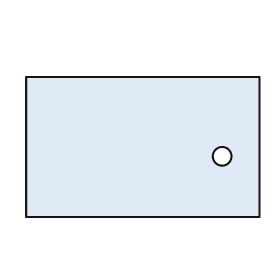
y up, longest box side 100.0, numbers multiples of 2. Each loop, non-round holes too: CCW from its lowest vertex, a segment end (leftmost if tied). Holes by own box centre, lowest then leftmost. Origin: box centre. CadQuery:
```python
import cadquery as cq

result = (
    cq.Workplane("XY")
    .moveTo(-50.0, -30.0)
    .lineTo(50.0, -30.0)
    .lineTo(50.0, 30.0)
    .lineTo(-50.0, 30.0)
    .close()
    .moveTo(34.0, -4.0)
    .circle(4.0)
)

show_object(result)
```